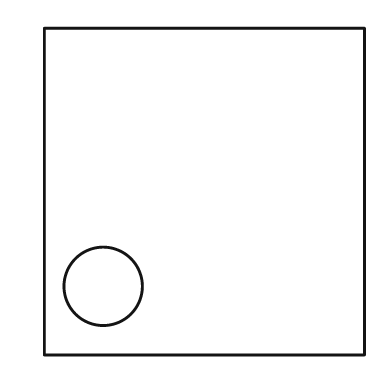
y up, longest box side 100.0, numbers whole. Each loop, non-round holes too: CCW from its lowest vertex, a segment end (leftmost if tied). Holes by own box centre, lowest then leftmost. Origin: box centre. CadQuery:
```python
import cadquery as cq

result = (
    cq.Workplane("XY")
    .moveTo(-49.0, -50.0)
    .lineTo(49.0, -50.0)
    .lineTo(49.0, 50.0)
    .lineTo(-49.0, 50.0)
    .close()
    .moveTo(-31.0, -29.0)
    .circle(12.0)
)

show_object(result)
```